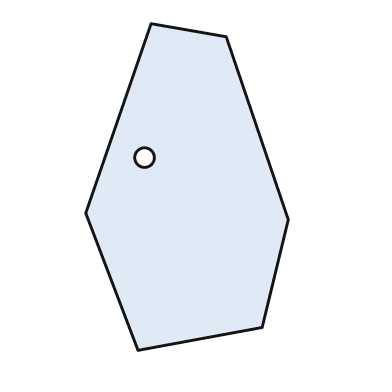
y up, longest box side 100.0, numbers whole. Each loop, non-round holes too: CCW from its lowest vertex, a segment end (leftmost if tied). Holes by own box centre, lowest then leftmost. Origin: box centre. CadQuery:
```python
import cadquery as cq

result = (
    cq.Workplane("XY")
    .moveTo(-15.0, -50.0)
    .lineTo(23.0, -43.0)
    .lineTo(31.0, -10.0)
    .lineTo(12.0, 46.0)
    .lineTo(-11.0, 50.0)
    .lineTo(-31.0, -8.0)
    .close()
    .moveTo(-13.0, 9.0)
    .circle(3.0)
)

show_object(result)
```